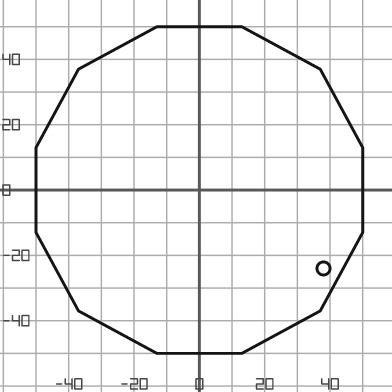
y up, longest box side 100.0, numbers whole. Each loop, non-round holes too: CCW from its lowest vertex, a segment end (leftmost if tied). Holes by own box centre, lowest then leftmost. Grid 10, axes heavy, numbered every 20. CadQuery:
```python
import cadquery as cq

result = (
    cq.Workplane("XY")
    .moveTo(-13.0, -50.0)
    .lineTo(13.0, -50.0)
    .lineTo(37.0, -37.0)
    .lineTo(50.0, -13.0)
    .lineTo(50.0, 13.0)
    .lineTo(37.0, 37.0)
    .lineTo(13.0, 50.0)
    .lineTo(-13.0, 50.0)
    .lineTo(-37.0, 37.0)
    .lineTo(-50.0, 13.0)
    .lineTo(-50.0, -13.0)
    .lineTo(-37.0, -37.0)
    .close()
    .moveTo(38.0, -24.0)
    .circle(2.0)
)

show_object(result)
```